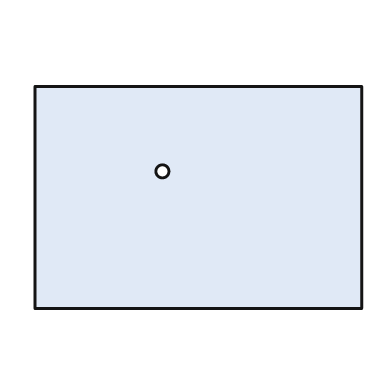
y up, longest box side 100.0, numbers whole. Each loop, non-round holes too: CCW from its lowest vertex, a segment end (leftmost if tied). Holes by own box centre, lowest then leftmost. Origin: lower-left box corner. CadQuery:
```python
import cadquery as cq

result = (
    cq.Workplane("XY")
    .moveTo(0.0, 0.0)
    .lineTo(100.0, 0.0)
    .lineTo(100.0, 68.0)
    .lineTo(0.0, 68.0)
    .close()
    .moveTo(39.0, 42.0)
    .circle(2.0)
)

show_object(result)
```